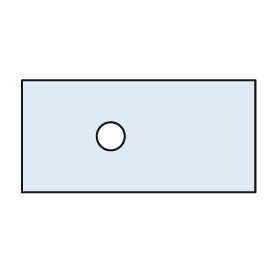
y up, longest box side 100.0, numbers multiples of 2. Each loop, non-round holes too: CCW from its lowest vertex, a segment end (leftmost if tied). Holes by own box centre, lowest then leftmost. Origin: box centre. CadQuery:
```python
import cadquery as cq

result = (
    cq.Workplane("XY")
    .moveTo(-50.0, -24.0)
    .lineTo(50.0, -24.0)
    .lineTo(50.0, 24.0)
    .lineTo(-50.0, 24.0)
    .close()
    .moveTo(-12.0, 0.0)
    .circle(6.0)
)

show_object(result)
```